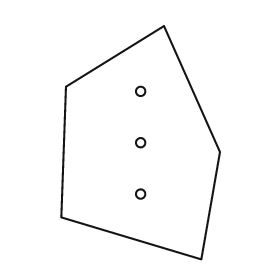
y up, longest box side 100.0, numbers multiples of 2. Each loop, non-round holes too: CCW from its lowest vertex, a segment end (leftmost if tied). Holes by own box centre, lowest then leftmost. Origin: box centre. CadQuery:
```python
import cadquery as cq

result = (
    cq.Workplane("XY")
    .moveTo(26.0, -50.0)
    .lineTo(34.0, -4.0)
    .lineTo(10.0, 50.0)
    .lineTo(-32.0, 24.0)
    .lineTo(-34.0, -32.0)
    .close()
    .moveTo(0.0, -22.0)
    .circle(2.0)
    .moveTo(0.0, 0.0)
    .circle(2.0)
    .moveTo(0.0, 22.0)
    .circle(2.0)
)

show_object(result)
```